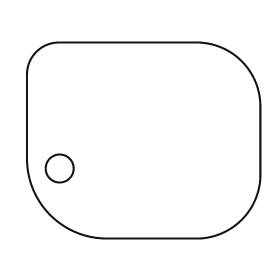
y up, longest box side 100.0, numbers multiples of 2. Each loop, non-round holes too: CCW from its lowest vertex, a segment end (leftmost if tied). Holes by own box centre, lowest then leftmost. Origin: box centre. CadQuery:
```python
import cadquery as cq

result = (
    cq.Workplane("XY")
    .moveTo(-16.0, -42.0)
    .lineTo(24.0, -42.0)
    .threePointArc((42.0, -34.0), (50.0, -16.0))
    .lineTo(50.0, 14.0)
    .threePointArc((42.0, 34.0), (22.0, 42.0))
    .lineTo(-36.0, 42.0)
    .threePointArc((-46.0, 38.0), (-50.0, 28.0))
    .lineTo(-50.0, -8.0)
    .threePointArc((-40.0, -32.0), (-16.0, -42.0))
    .close()
    .moveTo(-36.0, -12.0)
    .circle(6.0)
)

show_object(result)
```